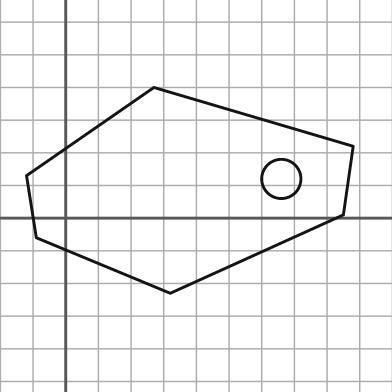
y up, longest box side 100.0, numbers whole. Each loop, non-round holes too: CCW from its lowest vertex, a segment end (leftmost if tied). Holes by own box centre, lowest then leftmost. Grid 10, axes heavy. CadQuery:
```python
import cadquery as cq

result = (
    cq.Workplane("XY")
    .moveTo(32.0, -23.0)
    .lineTo(85.0, 1.0)
    .lineTo(88.0, 22.0)
    .lineTo(27.0, 40.0)
    .lineTo(-12.0, 13.0)
    .lineTo(-9.0, -6.0)
    .close()
    .moveTo(66.0, 12.0)
    .circle(6.0)
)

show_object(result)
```